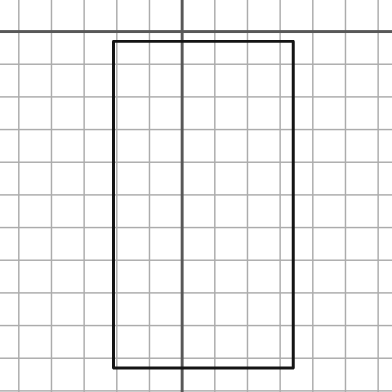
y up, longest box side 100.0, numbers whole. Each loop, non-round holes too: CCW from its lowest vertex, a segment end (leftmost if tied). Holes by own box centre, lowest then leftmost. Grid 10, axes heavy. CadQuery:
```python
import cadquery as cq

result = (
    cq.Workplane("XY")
    .moveTo(-21.0, -103.0)
    .lineTo(34.0, -103.0)
    .lineTo(34.0, -3.0)
    .lineTo(-21.0, -3.0)
    .close()
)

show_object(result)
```